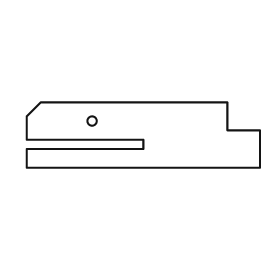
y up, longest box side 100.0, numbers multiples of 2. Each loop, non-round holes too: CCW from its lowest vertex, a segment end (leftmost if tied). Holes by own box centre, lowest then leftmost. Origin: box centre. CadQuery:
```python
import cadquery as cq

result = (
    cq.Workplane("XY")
    .moveTo(-50.0, -14.0)
    .lineTo(50.0, -14.0)
    .lineTo(50.0, 2.0)
    .lineTo(36.0, 2.0)
    .lineTo(36.0, 14.0)
    .lineTo(-44.0, 14.0)
    .lineTo(-50.0, 8.0)
    .lineTo(-50.0, -2.0)
    .lineTo(0.0, -2.0)
    .lineTo(0.0, -6.0)
    .lineTo(-50.0, -6.0)
    .close()
    .moveTo(-22.0, 6.0)
    .circle(2.0)
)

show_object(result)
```